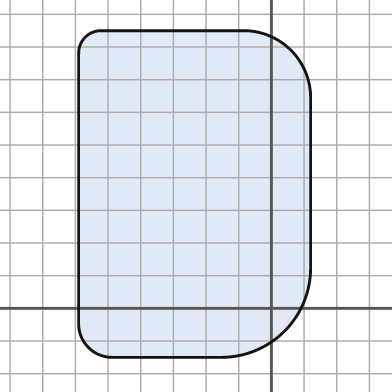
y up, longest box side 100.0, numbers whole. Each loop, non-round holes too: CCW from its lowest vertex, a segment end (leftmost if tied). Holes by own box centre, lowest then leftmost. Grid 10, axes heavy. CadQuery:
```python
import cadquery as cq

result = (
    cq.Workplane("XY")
    .moveTo(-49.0, -15.0)
    .lineTo(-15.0, -15.0)
    .threePointArc((4.0, -7.0), (12.0, 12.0))
    .lineTo(12.0, 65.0)
    .threePointArc((6.0, 79.0), (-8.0, 85.0))
    .lineTo(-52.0, 85.0)
    .threePointArc((-57.0, 83.0), (-59.0, 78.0))
    .lineTo(-59.0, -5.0)
    .threePointArc((-56.0, -12.0), (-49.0, -15.0))
    .close()
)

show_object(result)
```